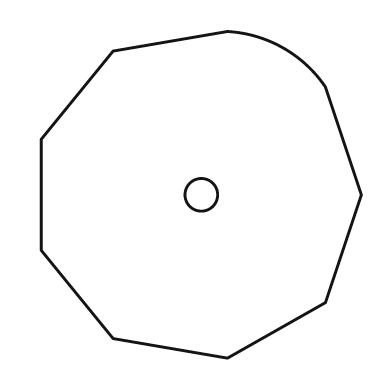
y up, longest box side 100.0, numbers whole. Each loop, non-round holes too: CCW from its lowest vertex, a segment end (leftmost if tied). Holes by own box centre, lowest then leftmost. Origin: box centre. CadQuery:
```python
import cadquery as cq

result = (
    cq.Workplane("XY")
    .moveTo(8.0, -50.0)
    .lineTo(38.0, -33.0)
    .lineTo(49.0, 0.0)
    .lineTo(38.0, 33.0)
    .threePointArc((25.0, 45.0), (8.0, 50.0))
    .lineTo(-27.0, 44.0)
    .lineTo(-49.0, 17.0)
    .lineTo(-49.0, -17.0)
    .lineTo(-27.0, -44.0)
    .close()
    .moveTo(0.0, 0.0)
    .circle(5.0)
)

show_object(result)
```